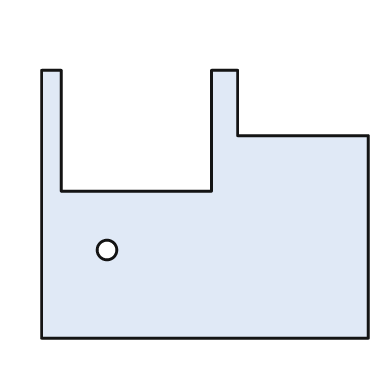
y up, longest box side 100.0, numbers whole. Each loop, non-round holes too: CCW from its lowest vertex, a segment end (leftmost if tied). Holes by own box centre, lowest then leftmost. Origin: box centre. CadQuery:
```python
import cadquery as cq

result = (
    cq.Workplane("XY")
    .moveTo(-50.0, -41.0)
    .lineTo(50.0, -41.0)
    .lineTo(50.0, 21.0)
    .lineTo(10.0, 21.0)
    .lineTo(10.0, 41.0)
    .lineTo(2.0, 41.0)
    .lineTo(2.0, 4.0)
    .lineTo(-44.0, 4.0)
    .lineTo(-44.0, 41.0)
    .lineTo(-50.0, 41.0)
    .close()
    .moveTo(-30.0, -14.0)
    .circle(3.0)
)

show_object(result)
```